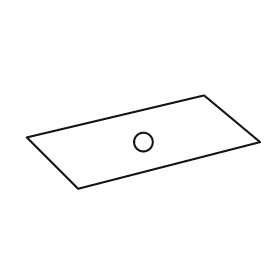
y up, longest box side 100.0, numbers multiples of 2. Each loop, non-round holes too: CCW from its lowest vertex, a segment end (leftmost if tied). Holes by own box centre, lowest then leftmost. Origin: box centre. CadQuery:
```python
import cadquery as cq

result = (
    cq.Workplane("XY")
    .moveTo(-28.0, -20.0)
    .lineTo(50.0, 0.0)
    .lineTo(26.0, 20.0)
    .lineTo(-50.0, 2.0)
    .close()
    .moveTo(0.0, 0.0)
    .circle(4.0)
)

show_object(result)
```